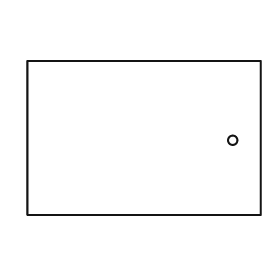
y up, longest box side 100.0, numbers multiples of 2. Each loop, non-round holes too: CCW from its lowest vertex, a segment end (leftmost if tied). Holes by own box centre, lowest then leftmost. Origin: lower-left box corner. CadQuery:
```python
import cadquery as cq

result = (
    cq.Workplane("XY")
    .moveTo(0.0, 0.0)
    .lineTo(100.0, 0.0)
    .lineTo(100.0, 66.0)
    .lineTo(0.0, 66.0)
    .close()
    .moveTo(88.0, 32.0)
    .circle(2.0)
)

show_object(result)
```